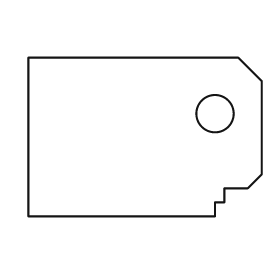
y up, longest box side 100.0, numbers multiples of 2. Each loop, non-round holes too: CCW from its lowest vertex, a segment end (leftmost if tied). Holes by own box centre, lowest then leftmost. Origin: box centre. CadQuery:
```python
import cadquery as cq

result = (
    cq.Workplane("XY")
    .moveTo(-50.0, -34.0)
    .lineTo(30.0, -34.0)
    .lineTo(30.0, -28.0)
    .lineTo(34.0, -28.0)
    .lineTo(34.0, -22.0)
    .lineTo(44.0, -22.0)
    .lineTo(50.0, -16.0)
    .lineTo(50.0, 24.0)
    .lineTo(40.0, 34.0)
    .lineTo(-50.0, 34.0)
    .close()
    .moveTo(30.0, 10.0)
    .circle(8.0)
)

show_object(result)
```